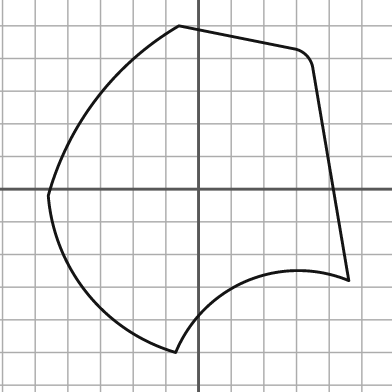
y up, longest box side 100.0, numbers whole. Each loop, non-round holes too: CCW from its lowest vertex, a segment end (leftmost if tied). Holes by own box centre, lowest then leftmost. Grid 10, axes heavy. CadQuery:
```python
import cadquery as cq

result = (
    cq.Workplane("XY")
    .moveTo(-7.0, -50.0)
    .threePointArc((15.0, -28.0), (46.0, -28.0))
    .lineTo(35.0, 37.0)
    .threePointArc((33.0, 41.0), (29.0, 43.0))
    .lineTo(-6.0, 50.0)
    .threePointArc((-31.0, 28.0), (-46.0, -2.0))
    .threePointArc((-34.0, -32.0), (-7.0, -50.0))
    .close()
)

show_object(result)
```